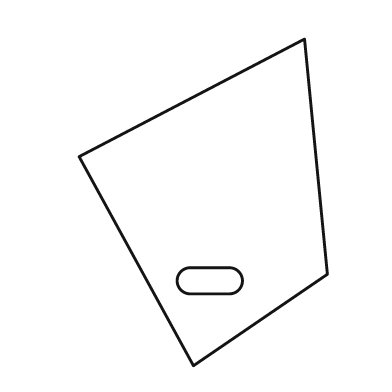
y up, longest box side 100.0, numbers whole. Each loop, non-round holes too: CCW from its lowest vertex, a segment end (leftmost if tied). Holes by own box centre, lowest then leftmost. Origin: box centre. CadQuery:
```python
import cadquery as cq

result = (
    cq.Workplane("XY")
    .moveTo(-3.0, -50.0)
    .lineTo(38.0, -22.0)
    .lineTo(31.0, 50.0)
    .lineTo(-38.0, 14.0)
    .close()
    .moveTo(-4.0, -28.0)
    .lineTo(8.0, -28.0)
    .threePointArc((12.0, -24.0), (8.0, -20.0))
    .lineTo(-4.0, -20.0)
    .threePointArc((-8.0, -24.0), (-4.0, -28.0))
    .close()
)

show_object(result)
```